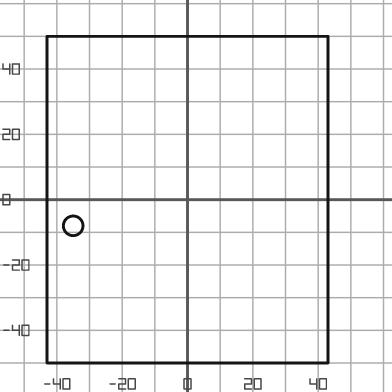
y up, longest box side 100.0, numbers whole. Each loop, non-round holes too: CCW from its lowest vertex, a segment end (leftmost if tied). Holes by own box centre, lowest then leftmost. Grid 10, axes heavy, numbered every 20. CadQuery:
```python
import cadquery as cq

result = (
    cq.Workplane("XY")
    .moveTo(-43.0, -50.0)
    .lineTo(43.0, -50.0)
    .lineTo(43.0, 50.0)
    .lineTo(-43.0, 50.0)
    .close()
    .moveTo(-35.0, -8.0)
    .circle(3.0)
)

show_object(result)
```